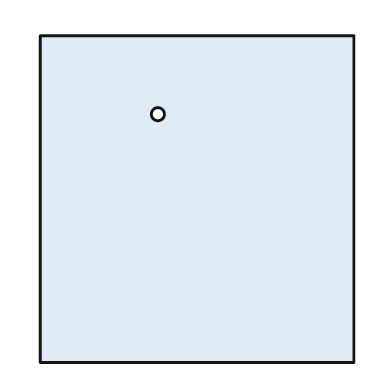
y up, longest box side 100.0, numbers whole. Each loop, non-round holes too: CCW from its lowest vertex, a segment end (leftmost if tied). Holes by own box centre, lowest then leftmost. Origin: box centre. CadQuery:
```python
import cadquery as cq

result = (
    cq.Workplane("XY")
    .moveTo(-48.0, -50.0)
    .lineTo(48.0, -50.0)
    .lineTo(48.0, 50.0)
    .lineTo(-48.0, 50.0)
    .close()
    .moveTo(-12.0, 26.0)
    .circle(2.0)
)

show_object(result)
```